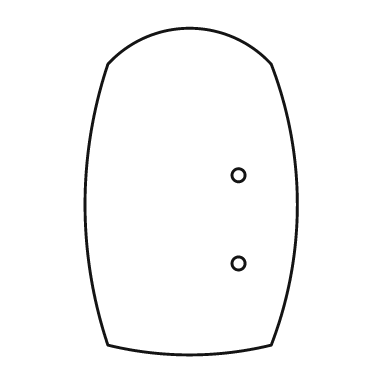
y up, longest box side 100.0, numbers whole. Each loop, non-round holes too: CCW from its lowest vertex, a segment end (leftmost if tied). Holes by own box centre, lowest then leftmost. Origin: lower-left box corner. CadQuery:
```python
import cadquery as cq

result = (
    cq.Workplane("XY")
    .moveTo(7.0, 3.0)
    .threePointArc((32.0, 0.0), (57.0, 3.0))
    .threePointArc((65.0, 46.0), (57.0, 89.0))
    .threePointArc((32.0, 100.0), (7.0, 89.0))
    .threePointArc((0.0, 46.0), (7.0, 3.0))
    .close()
    .moveTo(47.0, 28.0)
    .circle(2.0)
    .moveTo(47.0, 55.0)
    .circle(2.0)
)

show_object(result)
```